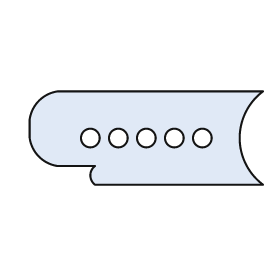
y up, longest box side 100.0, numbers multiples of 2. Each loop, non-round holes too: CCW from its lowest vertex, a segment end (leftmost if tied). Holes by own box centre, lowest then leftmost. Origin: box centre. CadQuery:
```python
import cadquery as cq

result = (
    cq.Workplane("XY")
    .moveTo(-22.0, -20.0)
    .lineTo(50.0, -20.0)
    .threePointArc((40.0, 0.0), (50.0, 20.0))
    .lineTo(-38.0, 20.0)
    .threePointArc((-46.0, 16.0), (-50.0, 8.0))
    .lineTo(-50.0, 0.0)
    .threePointArc((-46.0, -8.0), (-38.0, -12.0))
    .lineTo(-22.0, -12.0)
    .threePointArc((-24.0, -16.0), (-22.0, -20.0))
    .close()
    .moveTo(-24.0, 0.0)
    .circle(4.0)
    .moveTo(-12.0, 0.0)
    .circle(4.0)
    .moveTo(0.0, 0.0)
    .circle(4.0)
    .moveTo(12.0, 0.0)
    .circle(4.0)
    .moveTo(24.0, 0.0)
    .circle(4.0)
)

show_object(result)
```